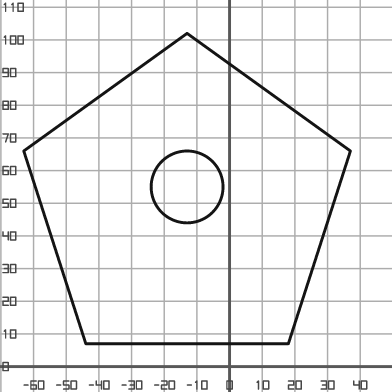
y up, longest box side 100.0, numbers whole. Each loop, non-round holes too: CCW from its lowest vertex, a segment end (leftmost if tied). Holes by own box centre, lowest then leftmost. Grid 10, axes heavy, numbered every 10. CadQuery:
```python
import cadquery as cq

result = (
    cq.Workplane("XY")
    .moveTo(-44.0, 7.0)
    .lineTo(18.0, 7.0)
    .lineTo(37.0, 66.0)
    .lineTo(-13.0, 102.0)
    .lineTo(-63.0, 66.0)
    .close()
    .moveTo(-13.0, 55.0)
    .circle(11.0)
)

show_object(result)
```